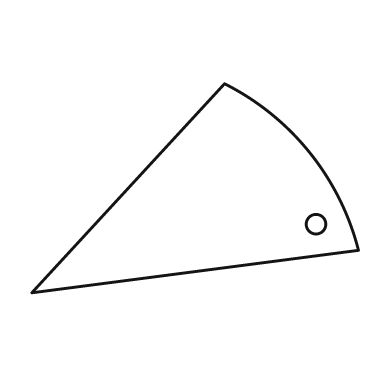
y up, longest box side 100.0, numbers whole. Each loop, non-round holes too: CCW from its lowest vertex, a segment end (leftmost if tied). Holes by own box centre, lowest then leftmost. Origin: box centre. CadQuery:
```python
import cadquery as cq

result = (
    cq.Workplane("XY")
    .moveTo(-50.0, -32.0)
    .lineTo(50.0, -19.0)
    .threePointArc((35.0, 11.0), (9.0, 32.0))
    .close()
    .moveTo(37.0, -11.0)
    .circle(3.0)
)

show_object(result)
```